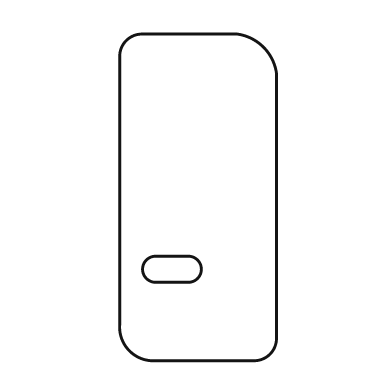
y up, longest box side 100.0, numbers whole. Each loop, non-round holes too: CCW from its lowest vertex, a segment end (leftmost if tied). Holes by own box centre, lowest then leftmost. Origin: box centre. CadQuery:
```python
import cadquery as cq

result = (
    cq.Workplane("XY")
    .moveTo(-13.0, -50.0)
    .lineTo(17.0, -50.0)
    .threePointArc((22.0, -48.0), (24.0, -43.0))
    .lineTo(24.0, 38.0)
    .threePointArc((20.0, 46.0), (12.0, 50.0))
    .lineTo(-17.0, 50.0)
    .threePointArc((-22.0, 48.0), (-24.0, 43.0))
    .lineTo(-24.0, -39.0)
    .threePointArc((-21.0, -47.0), (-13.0, -50.0))
    .close()
    .moveTo(-13.0, -26.0)
    .lineTo(-3.0, -26.0)
    .threePointArc((1.0, -22.0), (-3.0, -18.0))
    .lineTo(-13.0, -18.0)
    .threePointArc((-17.0, -22.0), (-13.0, -26.0))
    .close()
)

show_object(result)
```